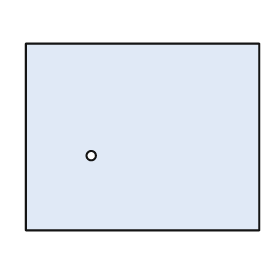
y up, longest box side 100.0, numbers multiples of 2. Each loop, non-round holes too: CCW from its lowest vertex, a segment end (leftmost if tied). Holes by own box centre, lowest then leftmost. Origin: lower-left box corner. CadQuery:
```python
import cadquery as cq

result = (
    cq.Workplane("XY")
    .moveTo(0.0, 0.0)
    .lineTo(100.0, 0.0)
    .lineTo(100.0, 80.0)
    .lineTo(0.0, 80.0)
    .close()
    .moveTo(28.0, 32.0)
    .circle(2.0)
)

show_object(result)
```